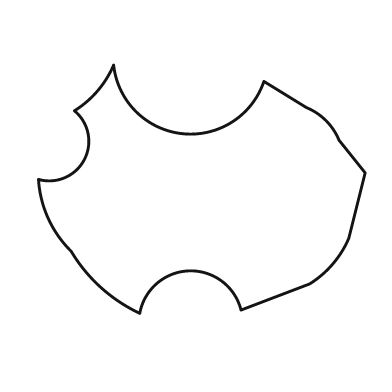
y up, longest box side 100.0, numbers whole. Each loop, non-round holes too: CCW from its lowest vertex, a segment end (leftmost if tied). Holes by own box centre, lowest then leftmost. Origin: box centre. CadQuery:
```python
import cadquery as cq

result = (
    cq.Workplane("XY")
    .moveTo(-19.0, -38.0)
    .threePointArc((-4.0, -25.0), (12.0, -37.0))
    .lineTo(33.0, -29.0)
    .threePointArc((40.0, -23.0), (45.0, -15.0))
    .lineTo(50.0, 5.0)
    .lineTo(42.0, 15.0)
    .threePointArc((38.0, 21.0), (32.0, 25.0))
    .lineTo(19.0, 33.0)
    .threePointArc((-6.0, 17.0), (-27.0, 38.0))
    .threePointArc((-32.0, 30.0), (-39.0, 24.0))
    .threePointArc((-36.0, 9.0), (-50.0, 3.0))
    .threePointArc((-47.0, -9.0), (-40.0, -19.0))
    .threePointArc((-31.0, -30.0), (-19.0, -38.0))
    .close()
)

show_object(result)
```